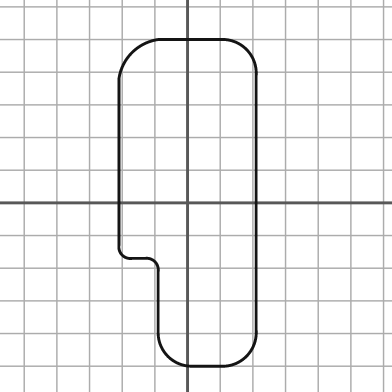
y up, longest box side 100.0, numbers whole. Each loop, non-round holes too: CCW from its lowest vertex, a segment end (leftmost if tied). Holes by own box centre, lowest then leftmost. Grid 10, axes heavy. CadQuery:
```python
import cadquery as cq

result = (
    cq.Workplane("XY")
    .moveTo(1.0, -50.0)
    .lineTo(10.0, -50.0)
    .threePointArc((18.0, -47.0), (21.0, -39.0))
    .lineTo(21.0, 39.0)
    .threePointArc((18.0, 47.0), (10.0, 50.0))
    .lineTo(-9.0, 50.0)
    .threePointArc((-17.0, 46.0), (-21.0, 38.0))
    .lineTo(-21.0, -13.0)
    .threePointArc((-20.0, -16.0), (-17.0, -17.0))
    .lineTo(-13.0, -17.0)
    .threePointArc((-10.0, -18.0), (-9.0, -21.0))
    .lineTo(-9.0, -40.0)
    .threePointArc((-6.0, -47.0), (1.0, -50.0))
    .close()
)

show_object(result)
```